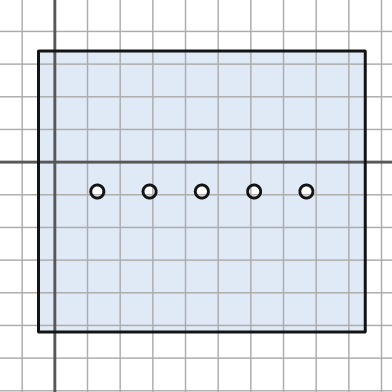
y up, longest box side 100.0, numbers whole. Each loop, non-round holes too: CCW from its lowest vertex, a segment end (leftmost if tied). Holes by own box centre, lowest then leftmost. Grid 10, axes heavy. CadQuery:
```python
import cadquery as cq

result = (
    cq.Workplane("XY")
    .moveTo(-5.0, -52.0)
    .lineTo(95.0, -52.0)
    .lineTo(95.0, 34.0)
    .lineTo(-5.0, 34.0)
    .close()
    .moveTo(13.0, -9.0)
    .circle(2.0)
    .moveTo(29.0, -9.0)
    .circle(2.0)
    .moveTo(45.0, -9.0)
    .circle(2.0)
    .moveTo(61.0, -9.0)
    .circle(2.0)
    .moveTo(77.0, -9.0)
    .circle(2.0)
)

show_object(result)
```